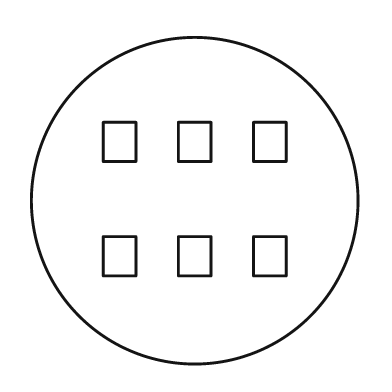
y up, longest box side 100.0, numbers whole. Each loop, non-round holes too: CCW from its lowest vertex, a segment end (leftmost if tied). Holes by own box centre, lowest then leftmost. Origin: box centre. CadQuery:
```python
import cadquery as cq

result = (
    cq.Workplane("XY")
    .moveTo(0.0, 0.0)
    .circle(50.0)
    .moveTo(-28.0, -23.0)
    .lineTo(-18.0, -23.0)
    .lineTo(-18.0, -11.0)
    .lineTo(-28.0, -11.0)
    .close()
    .moveTo(-5.0, -23.0)
    .lineTo(5.0, -23.0)
    .lineTo(5.0, -11.0)
    .lineTo(-5.0, -11.0)
    .close()
    .moveTo(18.0, -23.0)
    .lineTo(28.0, -23.0)
    .lineTo(28.0, -11.0)
    .lineTo(18.0, -11.0)
    .close()
    .moveTo(-28.0, 12.0)
    .lineTo(-18.0, 12.0)
    .lineTo(-18.0, 24.0)
    .lineTo(-28.0, 24.0)
    .close()
    .moveTo(-5.0, 12.0)
    .lineTo(5.0, 12.0)
    .lineTo(5.0, 24.0)
    .lineTo(-5.0, 24.0)
    .close()
    .moveTo(18.0, 12.0)
    .lineTo(28.0, 12.0)
    .lineTo(28.0, 24.0)
    .lineTo(18.0, 24.0)
    .close()
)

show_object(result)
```